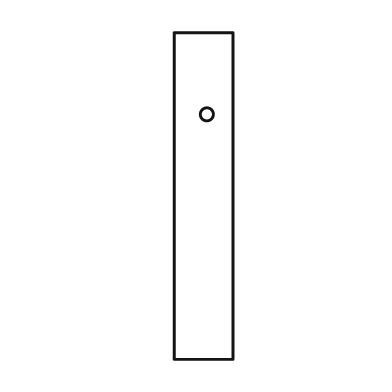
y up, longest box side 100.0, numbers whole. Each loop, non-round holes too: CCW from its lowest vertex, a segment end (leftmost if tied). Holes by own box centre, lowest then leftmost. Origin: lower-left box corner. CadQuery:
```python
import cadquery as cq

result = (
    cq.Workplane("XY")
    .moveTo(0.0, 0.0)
    .lineTo(18.0, 0.0)
    .lineTo(18.0, 100.0)
    .lineTo(0.0, 100.0)
    .close()
    .moveTo(10.0, 75.0)
    .circle(2.0)
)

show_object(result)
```